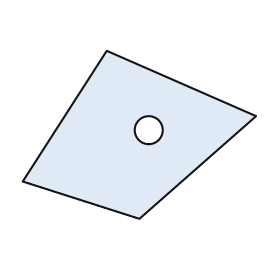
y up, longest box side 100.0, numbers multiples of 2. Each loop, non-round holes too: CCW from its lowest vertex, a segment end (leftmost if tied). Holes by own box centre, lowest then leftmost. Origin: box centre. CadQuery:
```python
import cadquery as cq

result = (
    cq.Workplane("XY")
    .moveTo(0.0, -36.0)
    .lineTo(50.0, 8.0)
    .lineTo(-14.0, 36.0)
    .lineTo(-50.0, -20.0)
    .close()
    .moveTo(4.0, 2.0)
    .circle(6.0)
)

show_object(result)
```